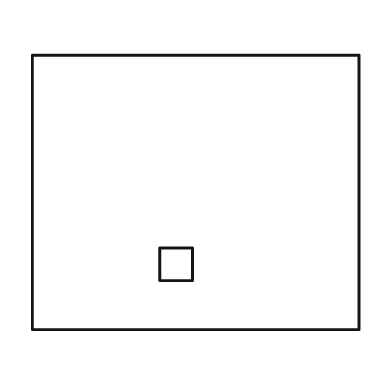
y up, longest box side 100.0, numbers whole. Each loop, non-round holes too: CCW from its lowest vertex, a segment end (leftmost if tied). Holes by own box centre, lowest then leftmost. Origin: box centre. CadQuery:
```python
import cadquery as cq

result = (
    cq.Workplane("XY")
    .moveTo(-50.0, -42.0)
    .lineTo(50.0, -42.0)
    .lineTo(50.0, 42.0)
    .lineTo(-50.0, 42.0)
    .close()
    .moveTo(-11.0, -27.0)
    .lineTo(-1.0, -27.0)
    .lineTo(-1.0, -17.0)
    .lineTo(-11.0, -17.0)
    .close()
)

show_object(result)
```